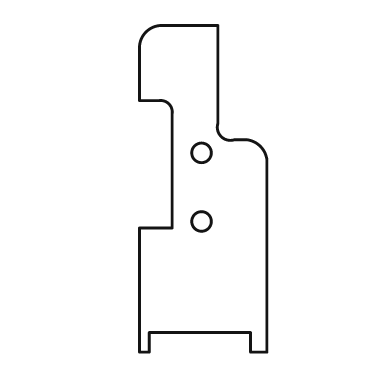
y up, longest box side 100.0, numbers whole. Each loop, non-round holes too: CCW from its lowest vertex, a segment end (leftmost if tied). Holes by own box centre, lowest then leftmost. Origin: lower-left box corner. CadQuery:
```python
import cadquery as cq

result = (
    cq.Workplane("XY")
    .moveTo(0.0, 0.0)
    .lineTo(3.0, 0.0)
    .lineTo(3.0, 6.0)
    .lineTo(34.0, 6.0)
    .lineTo(34.0, 0.0)
    .lineTo(39.0, 0.0)
    .lineTo(39.0, 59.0)
    .threePointArc((37.0, 63.0), (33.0, 65.0))
    .lineTo(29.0, 65.0)
    .threePointArc((25.0, 66.0), (24.0, 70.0))
    .lineTo(24.0, 100.0)
    .lineTo(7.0, 100.0)
    .threePointArc((2.0, 98.0), (0.0, 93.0))
    .lineTo(0.0, 77.0)
    .lineTo(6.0, 77.0)
    .threePointArc((9.0, 76.0), (10.0, 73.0))
    .lineTo(10.0, 38.0)
    .lineTo(0.0, 38.0)
    .close()
    .moveTo(19.0, 40.0)
    .circle(3.0)
    .moveTo(19.0, 61.0)
    .circle(3.0)
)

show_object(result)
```